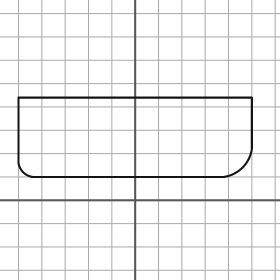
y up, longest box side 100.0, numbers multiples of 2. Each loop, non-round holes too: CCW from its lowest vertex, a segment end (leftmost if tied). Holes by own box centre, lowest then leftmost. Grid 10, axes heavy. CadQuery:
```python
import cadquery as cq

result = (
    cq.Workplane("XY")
    .moveTo(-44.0, 10.0)
    .lineTo(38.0, 10.0)
    .threePointArc((46.0, 14.0), (50.0, 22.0))
    .lineTo(50.0, 44.0)
    .lineTo(-50.0, 44.0)
    .lineTo(-50.0, 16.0)
    .threePointArc((-48.0, 12.0), (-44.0, 10.0))
    .close()
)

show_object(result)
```